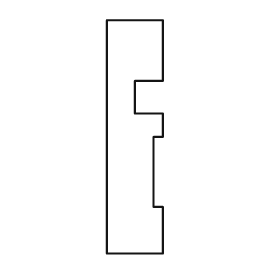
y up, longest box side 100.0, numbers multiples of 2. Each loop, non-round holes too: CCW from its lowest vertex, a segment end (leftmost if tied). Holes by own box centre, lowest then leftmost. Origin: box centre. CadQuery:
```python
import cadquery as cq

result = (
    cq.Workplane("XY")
    .moveTo(-12.0, -50.0)
    .lineTo(12.0, -50.0)
    .lineTo(12.0, -30.0)
    .lineTo(8.0, -30.0)
    .lineTo(8.0, 0.0)
    .lineTo(12.0, 0.0)
    .lineTo(12.0, 10.0)
    .lineTo(0.0, 10.0)
    .lineTo(0.0, 24.0)
    .lineTo(12.0, 24.0)
    .lineTo(12.0, 50.0)
    .lineTo(-12.0, 50.0)
    .close()
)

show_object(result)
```